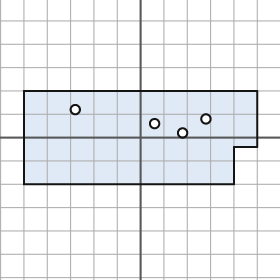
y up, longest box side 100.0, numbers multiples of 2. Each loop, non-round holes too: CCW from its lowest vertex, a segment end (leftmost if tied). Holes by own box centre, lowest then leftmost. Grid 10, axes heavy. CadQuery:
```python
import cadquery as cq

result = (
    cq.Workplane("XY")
    .moveTo(-50.0, -20.0)
    .lineTo(40.0, -20.0)
    .lineTo(40.0, -4.0)
    .lineTo(50.0, -4.0)
    .lineTo(50.0, 20.0)
    .lineTo(-50.0, 20.0)
    .close()
    .moveTo(18.0, 2.0)
    .circle(2.0)
    .moveTo(6.0, 6.0)
    .circle(2.0)
    .moveTo(28.0, 8.0)
    .circle(2.0)
    .moveTo(-28.0, 12.0)
    .circle(2.0)
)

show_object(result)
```